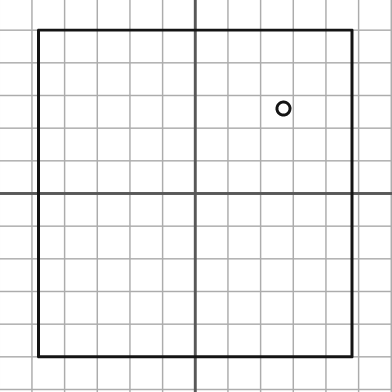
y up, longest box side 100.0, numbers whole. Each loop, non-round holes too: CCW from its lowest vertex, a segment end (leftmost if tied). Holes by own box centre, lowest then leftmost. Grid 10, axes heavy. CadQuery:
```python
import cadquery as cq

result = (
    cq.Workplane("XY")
    .moveTo(-48.0, -50.0)
    .lineTo(48.0, -50.0)
    .lineTo(48.0, 50.0)
    .lineTo(-48.0, 50.0)
    .close()
    .moveTo(27.0, 26.0)
    .circle(2.0)
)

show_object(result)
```